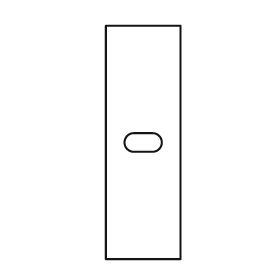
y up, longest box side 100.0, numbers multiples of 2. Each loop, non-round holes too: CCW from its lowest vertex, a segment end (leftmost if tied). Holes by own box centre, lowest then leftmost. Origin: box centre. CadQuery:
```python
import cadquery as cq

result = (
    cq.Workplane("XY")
    .moveTo(-16.0, -50.0)
    .lineTo(16.0, -50.0)
    .lineTo(16.0, 50.0)
    .lineTo(-16.0, 50.0)
    .close()
    .moveTo(-4.0, -4.0)
    .lineTo(4.0, -4.0)
    .threePointArc((8.0, 0.0), (4.0, 4.0))
    .lineTo(-4.0, 4.0)
    .threePointArc((-8.0, 0.0), (-4.0, -4.0))
    .close()
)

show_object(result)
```